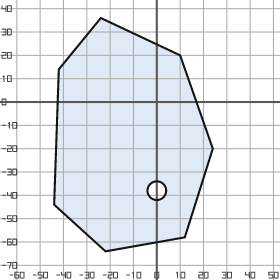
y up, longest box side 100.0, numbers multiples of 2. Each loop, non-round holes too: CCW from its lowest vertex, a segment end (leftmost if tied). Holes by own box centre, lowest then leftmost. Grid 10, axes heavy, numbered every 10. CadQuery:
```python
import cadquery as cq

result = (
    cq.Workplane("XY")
    .moveTo(-22.0, -64.0)
    .lineTo(12.0, -58.0)
    .lineTo(24.0, -20.0)
    .lineTo(10.0, 20.0)
    .lineTo(-24.0, 36.0)
    .lineTo(-42.0, 14.0)
    .lineTo(-44.0, -44.0)
    .close()
    .moveTo(0.0, -38.0)
    .circle(4.0)
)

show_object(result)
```